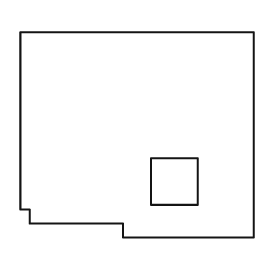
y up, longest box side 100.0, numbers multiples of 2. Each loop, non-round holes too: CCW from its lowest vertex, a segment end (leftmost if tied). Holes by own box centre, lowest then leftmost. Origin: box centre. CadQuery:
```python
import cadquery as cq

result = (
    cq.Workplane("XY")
    .moveTo(-6.0, -44.0)
    .lineTo(50.0, -44.0)
    .lineTo(50.0, 44.0)
    .lineTo(-50.0, 44.0)
    .lineTo(-50.0, -32.0)
    .lineTo(-46.0, -32.0)
    .lineTo(-46.0, -38.0)
    .lineTo(-6.0, -38.0)
    .close()
    .moveTo(6.0, -30.0)
    .lineTo(26.0, -30.0)
    .lineTo(26.0, -10.0)
    .lineTo(6.0, -10.0)
    .close()
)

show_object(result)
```